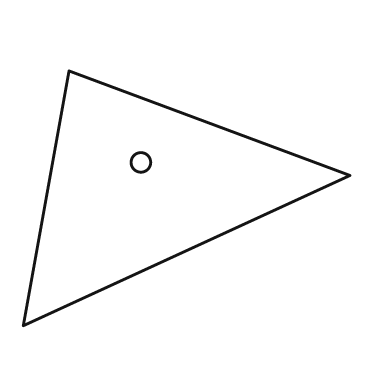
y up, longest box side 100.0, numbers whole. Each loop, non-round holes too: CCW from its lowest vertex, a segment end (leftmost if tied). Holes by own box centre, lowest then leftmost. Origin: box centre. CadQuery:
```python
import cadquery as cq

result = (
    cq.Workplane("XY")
    .moveTo(-50.0, -39.0)
    .lineTo(50.0, 7.0)
    .lineTo(-36.0, 39.0)
    .close()
    .moveTo(-14.0, 11.0)
    .circle(3.0)
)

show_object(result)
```